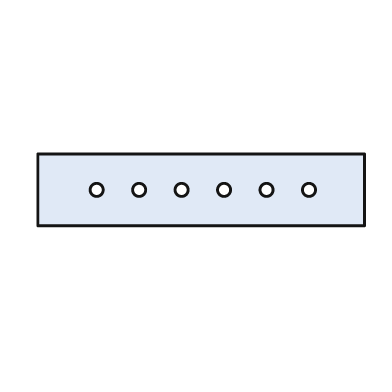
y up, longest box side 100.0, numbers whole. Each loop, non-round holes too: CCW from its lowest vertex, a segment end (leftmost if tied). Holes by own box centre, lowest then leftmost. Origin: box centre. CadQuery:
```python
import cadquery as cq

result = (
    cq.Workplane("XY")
    .moveTo(-50.0, -11.0)
    .lineTo(50.0, -11.0)
    .lineTo(50.0, 11.0)
    .lineTo(-50.0, 11.0)
    .close()
    .moveTo(-32.0, 0.0)
    .circle(2.0)
    .moveTo(-19.0, 0.0)
    .circle(2.0)
    .moveTo(-6.0, 0.0)
    .circle(2.0)
    .moveTo(7.0, 0.0)
    .circle(2.0)
    .moveTo(20.0, 0.0)
    .circle(2.0)
    .moveTo(33.0, 0.0)
    .circle(2.0)
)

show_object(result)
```